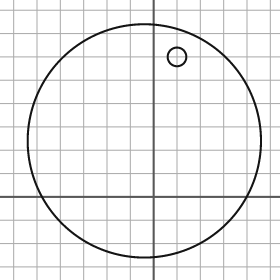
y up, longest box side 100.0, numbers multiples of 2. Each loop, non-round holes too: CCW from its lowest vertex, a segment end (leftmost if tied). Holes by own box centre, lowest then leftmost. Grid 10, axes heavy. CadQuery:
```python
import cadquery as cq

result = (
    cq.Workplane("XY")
    .moveTo(-4.0, 24.0)
    .circle(50.0)
    .moveTo(10.0, 60.0)
    .circle(4.0)
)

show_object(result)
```